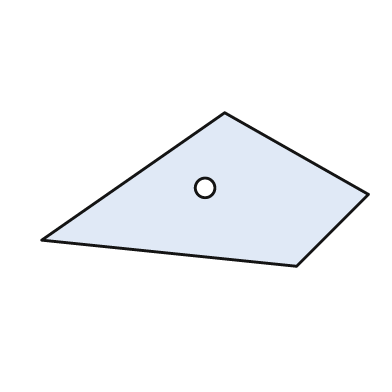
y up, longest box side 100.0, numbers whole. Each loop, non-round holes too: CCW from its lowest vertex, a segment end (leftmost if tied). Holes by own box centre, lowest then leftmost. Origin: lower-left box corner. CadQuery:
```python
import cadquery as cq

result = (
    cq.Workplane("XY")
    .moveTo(78.0, 0.0)
    .lineTo(100.0, 22.0)
    .lineTo(56.0, 47.0)
    .lineTo(0.0, 8.0)
    .close()
    .moveTo(50.0, 24.0)
    .circle(3.0)
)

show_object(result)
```